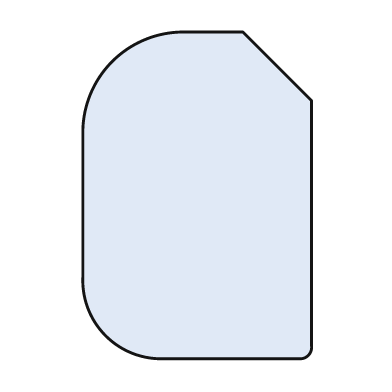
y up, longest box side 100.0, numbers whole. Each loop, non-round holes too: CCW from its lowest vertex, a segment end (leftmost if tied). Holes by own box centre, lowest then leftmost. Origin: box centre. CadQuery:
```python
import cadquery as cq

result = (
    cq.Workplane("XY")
    .moveTo(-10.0, -50.0)
    .lineTo(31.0, -50.0)
    .threePointArc((34.0, -49.0), (35.0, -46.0))
    .lineTo(35.0, 29.0)
    .lineTo(14.0, 50.0)
    .lineTo(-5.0, 50.0)
    .threePointArc((-26.0, 41.0), (-35.0, 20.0))
    .lineTo(-35.0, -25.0)
    .threePointArc((-28.0, -43.0), (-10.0, -50.0))
    .close()
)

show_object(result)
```